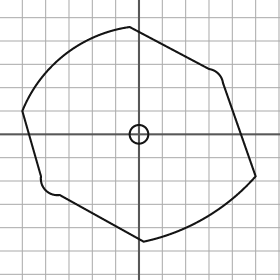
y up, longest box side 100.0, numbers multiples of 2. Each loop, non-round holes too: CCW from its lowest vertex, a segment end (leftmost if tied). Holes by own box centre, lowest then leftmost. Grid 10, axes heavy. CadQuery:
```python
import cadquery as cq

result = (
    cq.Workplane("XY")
    .moveTo(2.0, -46.0)
    .threePointArc((28.0, -36.0), (50.0, -18.0))
    .lineTo(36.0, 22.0)
    .threePointArc((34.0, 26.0), (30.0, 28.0))
    .lineTo(-4.0, 46.0)
    .threePointArc((-32.0, 34.0), (-50.0, 10.0))
    .lineTo(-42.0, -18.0)
    .threePointArc((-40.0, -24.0), (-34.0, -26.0))
    .close()
    .moveTo(0.0, 0.0)
    .circle(4.0)
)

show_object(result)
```